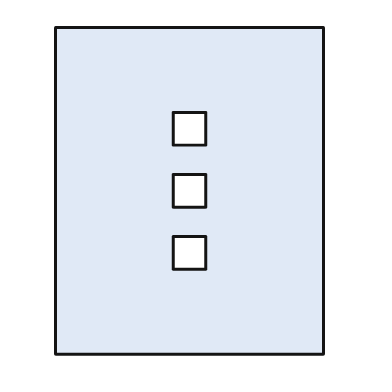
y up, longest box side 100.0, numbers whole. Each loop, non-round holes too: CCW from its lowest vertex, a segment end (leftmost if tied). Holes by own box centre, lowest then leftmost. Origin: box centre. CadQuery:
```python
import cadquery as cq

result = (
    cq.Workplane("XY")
    .moveTo(-41.0, -50.0)
    .lineTo(41.0, -50.0)
    .lineTo(41.0, 50.0)
    .lineTo(-41.0, 50.0)
    .close()
    .moveTo(-5.0, -24.0)
    .lineTo(5.0, -24.0)
    .lineTo(5.0, -14.0)
    .lineTo(-5.0, -14.0)
    .close()
    .moveTo(-5.0, -5.0)
    .lineTo(5.0, -5.0)
    .lineTo(5.0, 5.0)
    .lineTo(-5.0, 5.0)
    .close()
    .moveTo(-5.0, 14.0)
    .lineTo(5.0, 14.0)
    .lineTo(5.0, 24.0)
    .lineTo(-5.0, 24.0)
    .close()
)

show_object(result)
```